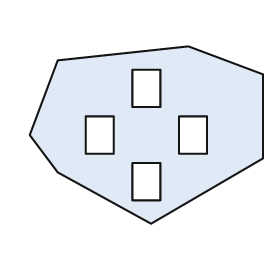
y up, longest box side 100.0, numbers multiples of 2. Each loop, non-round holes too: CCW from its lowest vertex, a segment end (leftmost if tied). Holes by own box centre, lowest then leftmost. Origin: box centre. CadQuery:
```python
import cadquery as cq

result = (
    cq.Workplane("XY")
    .moveTo(2.0, -38.0)
    .lineTo(50.0, -10.0)
    .lineTo(50.0, 26.0)
    .lineTo(18.0, 38.0)
    .lineTo(-38.0, 32.0)
    .lineTo(-50.0, 0.0)
    .lineTo(-38.0, -16.0)
    .close()
    .moveTo(-6.0, -28.0)
    .lineTo(6.0, -28.0)
    .lineTo(6.0, -12.0)
    .lineTo(-6.0, -12.0)
    .close()
    .moveTo(-26.0, -8.0)
    .lineTo(-14.0, -8.0)
    .lineTo(-14.0, 8.0)
    .lineTo(-26.0, 8.0)
    .close()
    .moveTo(14.0, -8.0)
    .lineTo(26.0, -8.0)
    .lineTo(26.0, 8.0)
    .lineTo(14.0, 8.0)
    .close()
    .moveTo(-6.0, 12.0)
    .lineTo(6.0, 12.0)
    .lineTo(6.0, 28.0)
    .lineTo(-6.0, 28.0)
    .close()
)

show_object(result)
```